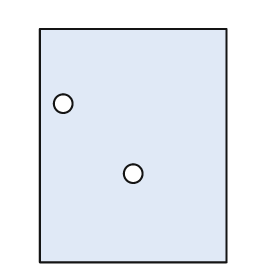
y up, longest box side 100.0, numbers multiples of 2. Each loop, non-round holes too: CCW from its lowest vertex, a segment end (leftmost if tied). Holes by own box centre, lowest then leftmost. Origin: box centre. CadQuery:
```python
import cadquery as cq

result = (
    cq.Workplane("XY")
    .moveTo(-40.0, -50.0)
    .lineTo(40.0, -50.0)
    .lineTo(40.0, 50.0)
    .lineTo(-40.0, 50.0)
    .close()
    .moveTo(0.0, -12.0)
    .circle(4.0)
    .moveTo(-30.0, 18.0)
    .circle(4.0)
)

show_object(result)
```